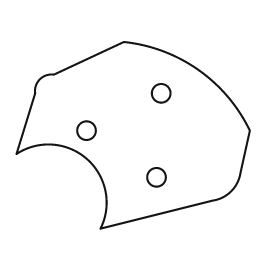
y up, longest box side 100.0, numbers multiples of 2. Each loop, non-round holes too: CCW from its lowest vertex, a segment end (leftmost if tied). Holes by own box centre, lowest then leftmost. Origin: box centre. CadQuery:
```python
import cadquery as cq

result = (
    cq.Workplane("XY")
    .moveTo(-14.0, -40.0)
    .lineTo(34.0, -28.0)
    .threePointArc((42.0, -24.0), (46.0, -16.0))
    .lineTo(50.0, 2.0)
    .threePointArc((28.0, 28.0), (-4.0, 40.0))
    .lineTo(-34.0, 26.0)
    .threePointArc((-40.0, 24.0), (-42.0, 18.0))
    .lineTo(-50.0, -8.0)
    .threePointArc((-20.0, -10.0), (-14.0, -40.0))
    .close()
    .moveTo(10.0, -18.0)
    .circle(4.0)
    .moveTo(-20.0, 2.0)
    .circle(4.0)
    .moveTo(12.0, 18.0)
    .circle(4.0)
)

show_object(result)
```